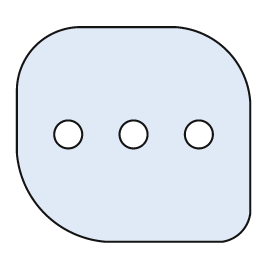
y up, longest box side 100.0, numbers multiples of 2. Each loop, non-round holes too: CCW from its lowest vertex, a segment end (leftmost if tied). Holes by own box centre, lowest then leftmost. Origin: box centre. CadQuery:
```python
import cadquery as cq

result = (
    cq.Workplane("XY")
    .moveTo(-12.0, -46.0)
    .lineTo(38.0, -46.0)
    .threePointArc((46.0, -42.0), (50.0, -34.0))
    .lineTo(50.0, 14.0)
    .threePointArc((40.0, 36.0), (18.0, 46.0))
    .lineTo(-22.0, 46.0)
    .threePointArc((-42.0, 38.0), (-50.0, 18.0))
    .lineTo(-50.0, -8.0)
    .threePointArc((-38.0, -34.0), (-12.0, -46.0))
    .close()
    .moveTo(-28.0, 0.0)
    .circle(6.0)
    .moveTo(0.0, 0.0)
    .circle(6.0)
    .moveTo(28.0, 0.0)
    .circle(6.0)
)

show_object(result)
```